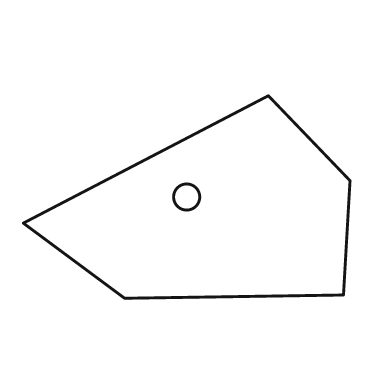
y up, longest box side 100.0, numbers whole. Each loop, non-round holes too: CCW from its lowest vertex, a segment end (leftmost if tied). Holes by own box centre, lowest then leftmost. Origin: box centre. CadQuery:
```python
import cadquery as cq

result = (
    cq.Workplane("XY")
    .moveTo(-19.0, -31.0)
    .lineTo(48.0, -30.0)
    .lineTo(50.0, 5.0)
    .lineTo(25.0, 31.0)
    .lineTo(-50.0, -8.0)
    .close()
    .moveTo(0.0, 0.0)
    .circle(4.0)
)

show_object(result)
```